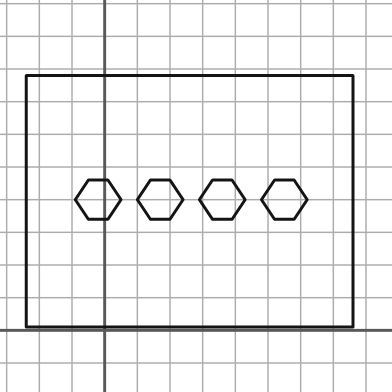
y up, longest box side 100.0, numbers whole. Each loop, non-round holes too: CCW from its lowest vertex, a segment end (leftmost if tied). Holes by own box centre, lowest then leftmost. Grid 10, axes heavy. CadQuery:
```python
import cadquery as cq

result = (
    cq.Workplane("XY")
    .moveTo(-24.0, 1.0)
    .lineTo(76.0, 1.0)
    .lineTo(76.0, 78.0)
    .lineTo(-24.0, 78.0)
    .close()
    .moveTo(-5.0, 34.0)
    .lineTo(1.0, 34.0)
    .lineTo(5.0, 40.0)
    .lineTo(1.0, 46.0)
    .lineTo(-5.0, 46.0)
    .lineTo(-9.0, 40.0)
    .close()
    .moveTo(14.0, 34.0)
    .lineTo(20.0, 34.0)
    .lineTo(24.0, 40.0)
    .lineTo(20.0, 46.0)
    .lineTo(14.0, 46.0)
    .lineTo(10.0, 40.0)
    .close()
    .moveTo(33.0, 34.0)
    .lineTo(39.0, 34.0)
    .lineTo(43.0, 40.0)
    .lineTo(39.0, 46.0)
    .lineTo(33.0, 46.0)
    .lineTo(29.0, 40.0)
    .close()
    .moveTo(52.0, 34.0)
    .lineTo(58.0, 34.0)
    .lineTo(62.0, 40.0)
    .lineTo(58.0, 46.0)
    .lineTo(52.0, 46.0)
    .lineTo(48.0, 40.0)
    .close()
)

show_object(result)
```